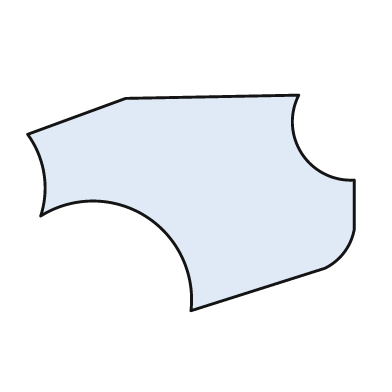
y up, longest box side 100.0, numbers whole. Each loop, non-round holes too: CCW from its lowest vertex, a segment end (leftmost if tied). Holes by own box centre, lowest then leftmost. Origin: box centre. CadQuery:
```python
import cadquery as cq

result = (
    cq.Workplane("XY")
    .moveTo(0.0, -33.0)
    .lineTo(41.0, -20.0)
    .threePointArc((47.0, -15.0), (50.0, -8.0))
    .lineTo(50.0, 7.0)
    .threePointArc((34.0, 15.0), (33.0, 33.0))
    .lineTo(-20.0, 32.0)
    .lineTo(-50.0, 21.0)
    .threePointArc((-45.0, 9.0), (-46.0, -4.0))
    .threePointArc((-14.0, -4.0), (0.0, -33.0))
    .close()
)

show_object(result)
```